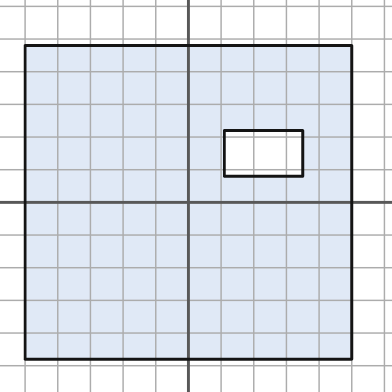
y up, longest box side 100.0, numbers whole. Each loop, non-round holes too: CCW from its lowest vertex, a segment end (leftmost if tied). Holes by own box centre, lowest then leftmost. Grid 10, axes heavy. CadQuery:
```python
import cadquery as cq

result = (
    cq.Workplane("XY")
    .moveTo(-50.0, -48.0)
    .lineTo(50.0, -48.0)
    .lineTo(50.0, 48.0)
    .lineTo(-50.0, 48.0)
    .close()
    .moveTo(11.0, 8.0)
    .lineTo(35.0, 8.0)
    .lineTo(35.0, 22.0)
    .lineTo(11.0, 22.0)
    .close()
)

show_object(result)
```